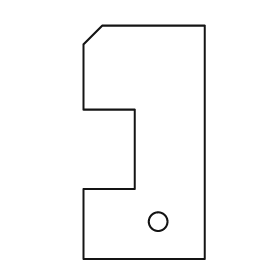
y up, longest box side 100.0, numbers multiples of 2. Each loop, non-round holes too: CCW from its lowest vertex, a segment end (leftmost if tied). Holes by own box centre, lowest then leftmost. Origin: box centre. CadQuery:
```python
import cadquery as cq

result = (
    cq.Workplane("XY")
    .moveTo(-26.0, -50.0)
    .lineTo(26.0, -50.0)
    .lineTo(26.0, 50.0)
    .lineTo(-18.0, 50.0)
    .lineTo(-26.0, 42.0)
    .lineTo(-26.0, 14.0)
    .lineTo(-4.0, 14.0)
    .lineTo(-4.0, -20.0)
    .lineTo(-26.0, -20.0)
    .close()
    .moveTo(6.0, -34.0)
    .circle(4.0)
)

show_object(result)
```